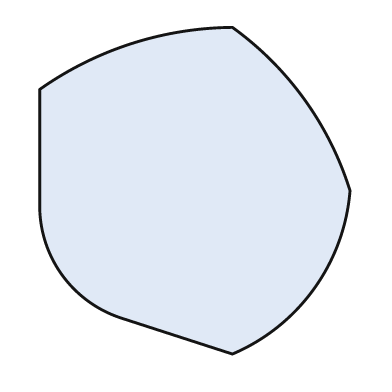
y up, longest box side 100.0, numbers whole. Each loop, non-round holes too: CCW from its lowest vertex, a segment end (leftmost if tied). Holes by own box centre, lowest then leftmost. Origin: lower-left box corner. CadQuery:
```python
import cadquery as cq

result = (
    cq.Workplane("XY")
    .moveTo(59.0, 0.0)
    .threePointArc((84.0, 20.0), (95.0, 50.0))
    .threePointArc((81.0, 78.0), (59.0, 100.0))
    .threePointArc((28.0, 95.0), (0.0, 81.0))
    .lineTo(0.0, 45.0)
    .threePointArc((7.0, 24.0), (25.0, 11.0))
    .close()
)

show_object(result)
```